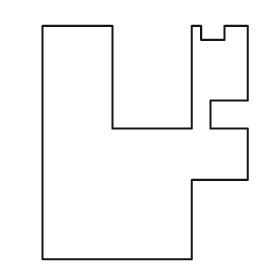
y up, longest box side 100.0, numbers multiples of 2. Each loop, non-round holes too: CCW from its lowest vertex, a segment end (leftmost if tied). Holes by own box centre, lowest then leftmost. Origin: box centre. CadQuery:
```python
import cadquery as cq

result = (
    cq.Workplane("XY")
    .moveTo(-44.0, -50.0)
    .lineTo(20.0, -50.0)
    .lineTo(20.0, -16.0)
    .lineTo(44.0, -16.0)
    .lineTo(44.0, 6.0)
    .lineTo(28.0, 6.0)
    .lineTo(28.0, 18.0)
    .lineTo(44.0, 18.0)
    .lineTo(44.0, 50.0)
    .lineTo(34.0, 50.0)
    .lineTo(34.0, 44.0)
    .lineTo(24.0, 44.0)
    .lineTo(24.0, 50.0)
    .lineTo(20.0, 50.0)
    .lineTo(20.0, 6.0)
    .lineTo(-14.0, 6.0)
    .lineTo(-14.0, 50.0)
    .lineTo(-44.0, 50.0)
    .close()
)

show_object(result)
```